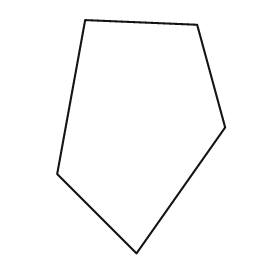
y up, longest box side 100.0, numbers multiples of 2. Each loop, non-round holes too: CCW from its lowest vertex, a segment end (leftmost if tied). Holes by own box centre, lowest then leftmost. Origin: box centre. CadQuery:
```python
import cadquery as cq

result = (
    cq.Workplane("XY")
    .moveTo(-2.0, -50.0)
    .lineTo(36.0, 4.0)
    .lineTo(24.0, 48.0)
    .lineTo(-24.0, 50.0)
    .lineTo(-36.0, -16.0)
    .close()
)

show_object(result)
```